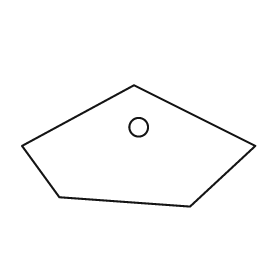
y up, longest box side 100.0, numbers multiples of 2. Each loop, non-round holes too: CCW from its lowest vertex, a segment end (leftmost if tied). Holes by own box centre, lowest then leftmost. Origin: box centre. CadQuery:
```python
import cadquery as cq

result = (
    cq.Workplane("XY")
    .moveTo(22.0, -26.0)
    .lineTo(50.0, 0.0)
    .lineTo(-2.0, 26.0)
    .lineTo(-50.0, 0.0)
    .lineTo(-34.0, -22.0)
    .close()
    .moveTo(0.0, 8.0)
    .circle(4.0)
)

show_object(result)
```